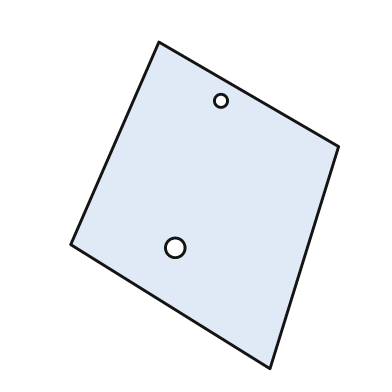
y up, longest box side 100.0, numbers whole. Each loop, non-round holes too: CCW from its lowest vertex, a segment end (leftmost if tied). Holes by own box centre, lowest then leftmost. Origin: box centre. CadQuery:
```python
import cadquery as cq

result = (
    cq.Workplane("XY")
    .moveTo(20.0, -50.0)
    .lineTo(41.0, 18.0)
    .lineTo(-14.0, 50.0)
    .lineTo(-41.0, -12.0)
    .close()
    .moveTo(-9.0, -13.0)
    .circle(3.0)
    .moveTo(5.0, 32.0)
    .circle(2.0)
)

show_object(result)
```